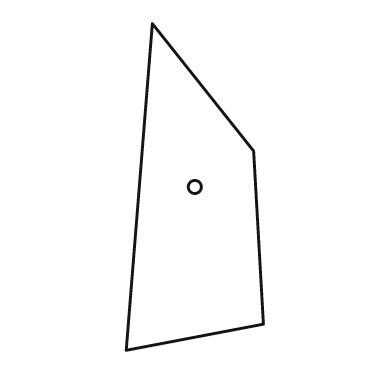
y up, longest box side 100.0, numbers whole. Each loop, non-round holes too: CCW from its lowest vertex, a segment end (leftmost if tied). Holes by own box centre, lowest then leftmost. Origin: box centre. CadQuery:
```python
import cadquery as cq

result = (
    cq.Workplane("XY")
    .moveTo(-21.0, -50.0)
    .lineTo(21.0, -42.0)
    .lineTo(18.0, 11.0)
    .lineTo(-13.0, 50.0)
    .close()
    .moveTo(0.0, 0.0)
    .circle(2.0)
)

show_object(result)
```